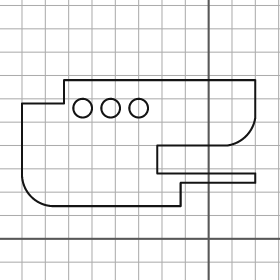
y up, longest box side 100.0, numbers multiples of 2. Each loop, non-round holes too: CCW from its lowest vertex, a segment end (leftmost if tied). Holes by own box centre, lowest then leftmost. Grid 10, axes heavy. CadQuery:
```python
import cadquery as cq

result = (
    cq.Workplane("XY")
    .moveTo(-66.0, 14.0)
    .lineTo(-12.0, 14.0)
    .lineTo(-12.0, 24.0)
    .lineTo(20.0, 24.0)
    .lineTo(20.0, 28.0)
    .lineTo(-22.0, 28.0)
    .lineTo(-22.0, 40.0)
    .lineTo(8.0, 40.0)
    .threePointArc((16.0, 44.0), (20.0, 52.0))
    .lineTo(20.0, 68.0)
    .lineTo(-62.0, 68.0)
    .lineTo(-62.0, 58.0)
    .lineTo(-80.0, 58.0)
    .lineTo(-80.0, 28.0)
    .threePointArc((-76.0, 18.0), (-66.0, 14.0))
    .close()
    .moveTo(-54.0, 56.0)
    .circle(4.0)
    .moveTo(-42.0, 56.0)
    .circle(4.0)
    .moveTo(-30.0, 56.0)
    .circle(4.0)
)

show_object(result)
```